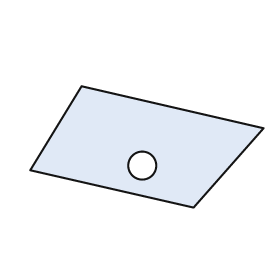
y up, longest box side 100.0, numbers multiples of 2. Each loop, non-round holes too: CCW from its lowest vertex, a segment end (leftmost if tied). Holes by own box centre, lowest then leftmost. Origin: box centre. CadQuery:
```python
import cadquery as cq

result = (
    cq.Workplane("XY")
    .moveTo(20.0, -26.0)
    .lineTo(50.0, 8.0)
    .lineTo(-28.0, 26.0)
    .lineTo(-50.0, -10.0)
    .close()
    .moveTo(-2.0, -8.0)
    .circle(6.0)
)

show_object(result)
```